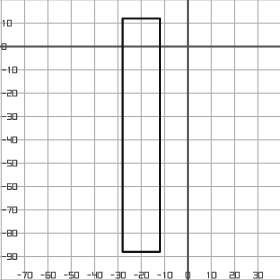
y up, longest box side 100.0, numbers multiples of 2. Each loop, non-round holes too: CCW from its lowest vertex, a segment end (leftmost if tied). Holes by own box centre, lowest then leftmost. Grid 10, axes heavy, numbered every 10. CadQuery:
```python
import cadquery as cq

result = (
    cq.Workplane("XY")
    .moveTo(-28.0, -88.0)
    .lineTo(-12.0, -88.0)
    .lineTo(-12.0, 12.0)
    .lineTo(-28.0, 12.0)
    .close()
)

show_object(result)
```